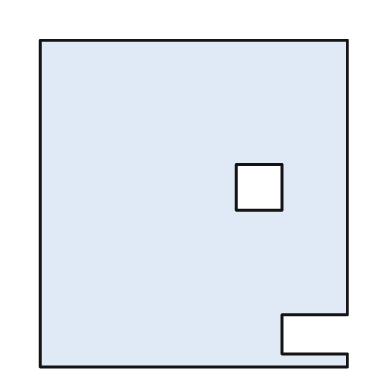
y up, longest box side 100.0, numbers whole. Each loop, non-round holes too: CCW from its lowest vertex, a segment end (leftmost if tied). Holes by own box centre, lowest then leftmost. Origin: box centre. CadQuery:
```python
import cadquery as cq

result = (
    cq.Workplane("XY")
    .moveTo(-47.0, -50.0)
    .lineTo(47.0, -50.0)
    .lineTo(47.0, -46.0)
    .lineTo(27.0, -46.0)
    .lineTo(27.0, -34.0)
    .lineTo(47.0, -34.0)
    .lineTo(47.0, 50.0)
    .lineTo(-47.0, 50.0)
    .close()
    .moveTo(13.0, -2.0)
    .lineTo(27.0, -2.0)
    .lineTo(27.0, 12.0)
    .lineTo(13.0, 12.0)
    .close()
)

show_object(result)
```